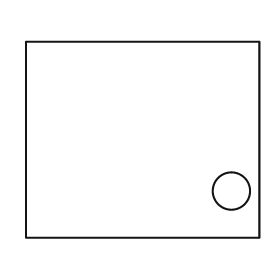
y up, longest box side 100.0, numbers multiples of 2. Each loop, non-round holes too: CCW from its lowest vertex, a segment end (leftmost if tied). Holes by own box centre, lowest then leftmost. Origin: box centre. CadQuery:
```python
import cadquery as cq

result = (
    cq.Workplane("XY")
    .moveTo(-50.0, -42.0)
    .lineTo(50.0, -42.0)
    .lineTo(50.0, 42.0)
    .lineTo(-50.0, 42.0)
    .close()
    .moveTo(38.0, -22.0)
    .circle(8.0)
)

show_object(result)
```